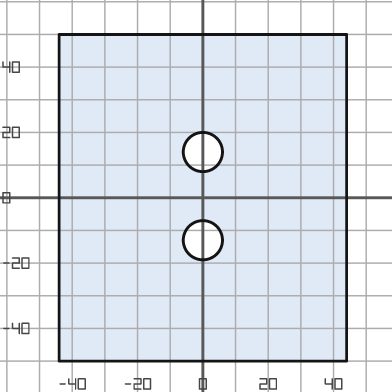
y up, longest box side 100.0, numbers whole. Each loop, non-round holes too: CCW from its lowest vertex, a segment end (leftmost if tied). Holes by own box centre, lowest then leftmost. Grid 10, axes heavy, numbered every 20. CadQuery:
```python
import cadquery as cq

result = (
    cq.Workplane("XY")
    .moveTo(-44.0, -50.0)
    .lineTo(44.0, -50.0)
    .lineTo(44.0, 50.0)
    .lineTo(-44.0, 50.0)
    .close()
    .moveTo(0.0, -13.0)
    .circle(6.0)
    .moveTo(0.0, 14.0)
    .circle(6.0)
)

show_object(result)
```